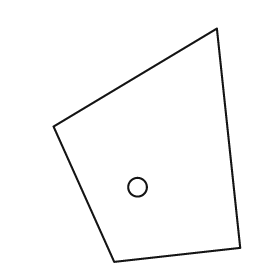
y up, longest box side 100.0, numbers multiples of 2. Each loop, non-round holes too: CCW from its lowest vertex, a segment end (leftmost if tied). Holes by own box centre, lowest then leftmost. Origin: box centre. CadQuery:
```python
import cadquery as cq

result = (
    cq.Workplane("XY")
    .moveTo(-14.0, -50.0)
    .lineTo(40.0, -44.0)
    .lineTo(30.0, 50.0)
    .lineTo(-40.0, 8.0)
    .close()
    .moveTo(-4.0, -18.0)
    .circle(4.0)
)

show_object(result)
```